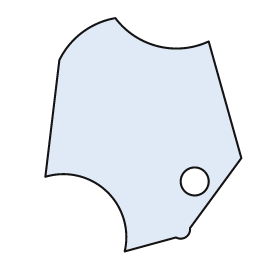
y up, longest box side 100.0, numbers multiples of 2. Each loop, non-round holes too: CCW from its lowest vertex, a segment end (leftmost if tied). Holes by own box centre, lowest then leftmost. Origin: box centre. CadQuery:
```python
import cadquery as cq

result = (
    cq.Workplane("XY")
    .moveTo(-8.0, -50.0)
    .lineTo(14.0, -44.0)
    .threePointArc((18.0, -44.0), (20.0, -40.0))
    .lineTo(42.0, -10.0)
    .lineTo(28.0, 40.0)
    .threePointArc((6.0, 38.0), (-12.0, 50.0))
    .threePointArc((-26.0, 44.0), (-36.0, 32.0))
    .lineTo(-42.0, -18.0)
    .threePointArc((-16.0, -24.0), (-8.0, -50.0))
    .close()
    .moveTo(22.0, -20.0)
    .circle(6.0)
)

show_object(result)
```